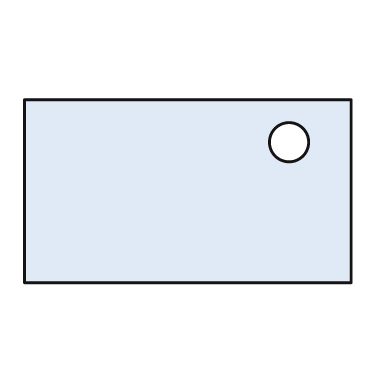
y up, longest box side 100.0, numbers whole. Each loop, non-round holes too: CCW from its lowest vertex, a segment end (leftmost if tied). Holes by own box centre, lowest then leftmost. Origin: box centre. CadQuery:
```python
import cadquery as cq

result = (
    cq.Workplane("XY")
    .moveTo(-50.0, -28.0)
    .lineTo(50.0, -28.0)
    .lineTo(50.0, 28.0)
    .lineTo(-50.0, 28.0)
    .close()
    .moveTo(31.0, 15.0)
    .circle(6.0)
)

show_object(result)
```